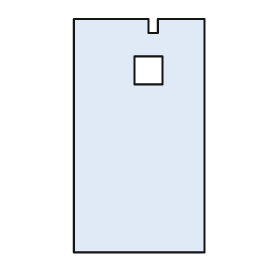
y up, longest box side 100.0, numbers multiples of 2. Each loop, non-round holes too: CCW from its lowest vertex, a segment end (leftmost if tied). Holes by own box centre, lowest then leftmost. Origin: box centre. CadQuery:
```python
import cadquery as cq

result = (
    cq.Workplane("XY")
    .moveTo(-28.0, -50.0)
    .lineTo(28.0, -50.0)
    .lineTo(28.0, 50.0)
    .lineTo(8.0, 50.0)
    .lineTo(8.0, 44.0)
    .lineTo(4.0, 44.0)
    .lineTo(4.0, 50.0)
    .lineTo(-28.0, 50.0)
    .close()
    .moveTo(-2.0, 22.0)
    .lineTo(10.0, 22.0)
    .lineTo(10.0, 34.0)
    .lineTo(-2.0, 34.0)
    .close()
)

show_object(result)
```